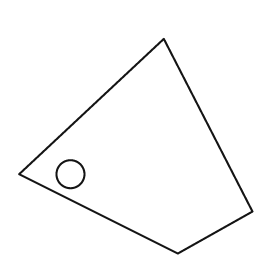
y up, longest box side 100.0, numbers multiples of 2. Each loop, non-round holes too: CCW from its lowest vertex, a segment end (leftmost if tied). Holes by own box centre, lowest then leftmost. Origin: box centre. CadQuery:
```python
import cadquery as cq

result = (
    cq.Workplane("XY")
    .moveTo(18.0, -46.0)
    .lineTo(50.0, -28.0)
    .lineTo(12.0, 46.0)
    .lineTo(-50.0, -12.0)
    .close()
    .moveTo(-28.0, -12.0)
    .circle(6.0)
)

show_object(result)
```